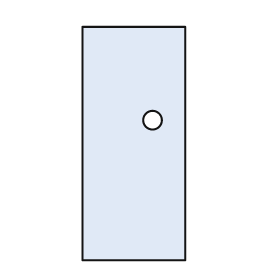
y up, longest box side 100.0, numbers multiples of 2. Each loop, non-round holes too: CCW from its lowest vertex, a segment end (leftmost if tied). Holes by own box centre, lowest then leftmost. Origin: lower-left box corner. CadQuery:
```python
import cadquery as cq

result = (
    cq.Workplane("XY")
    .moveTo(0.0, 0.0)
    .lineTo(44.0, 0.0)
    .lineTo(44.0, 100.0)
    .lineTo(0.0, 100.0)
    .close()
    .moveTo(30.0, 60.0)
    .circle(4.0)
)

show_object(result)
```